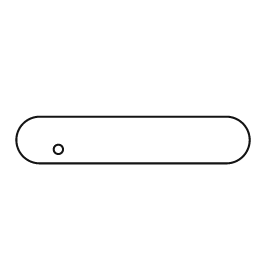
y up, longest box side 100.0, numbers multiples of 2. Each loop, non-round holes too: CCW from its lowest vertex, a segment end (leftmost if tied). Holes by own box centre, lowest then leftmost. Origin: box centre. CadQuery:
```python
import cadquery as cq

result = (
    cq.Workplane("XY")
    .moveTo(-40.0, -10.0)
    .lineTo(40.0, -10.0)
    .threePointArc((50.0, 0.0), (40.0, 10.0))
    .lineTo(-40.0, 10.0)
    .threePointArc((-50.0, 0.0), (-40.0, -10.0))
    .close()
    .moveTo(-32.0, -4.0)
    .circle(2.0)
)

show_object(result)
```